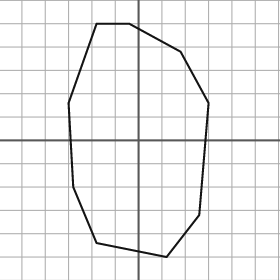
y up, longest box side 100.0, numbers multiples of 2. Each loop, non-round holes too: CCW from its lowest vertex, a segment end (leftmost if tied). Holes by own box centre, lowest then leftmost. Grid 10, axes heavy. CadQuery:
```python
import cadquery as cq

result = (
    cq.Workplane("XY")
    .moveTo(12.0, -50.0)
    .lineTo(26.0, -32.0)
    .lineTo(30.0, 16.0)
    .lineTo(18.0, 38.0)
    .lineTo(-4.0, 50.0)
    .lineTo(-18.0, 50.0)
    .lineTo(-30.0, 16.0)
    .lineTo(-28.0, -20.0)
    .lineTo(-18.0, -44.0)
    .close()
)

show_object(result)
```